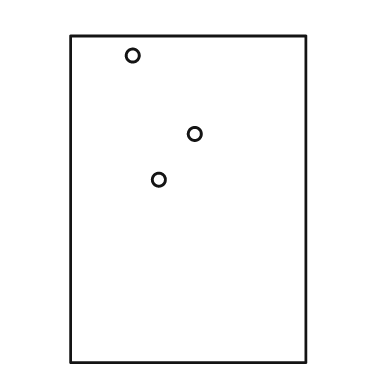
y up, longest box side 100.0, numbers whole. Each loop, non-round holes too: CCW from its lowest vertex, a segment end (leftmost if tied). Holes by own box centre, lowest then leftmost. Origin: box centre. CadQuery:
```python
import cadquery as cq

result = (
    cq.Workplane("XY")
    .moveTo(-36.0, -50.0)
    .lineTo(36.0, -50.0)
    .lineTo(36.0, 50.0)
    .lineTo(-36.0, 50.0)
    .close()
    .moveTo(-9.0, 6.0)
    .circle(2.0)
    .moveTo(2.0, 20.0)
    .circle(2.0)
    .moveTo(-17.0, 44.0)
    .circle(2.0)
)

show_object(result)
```